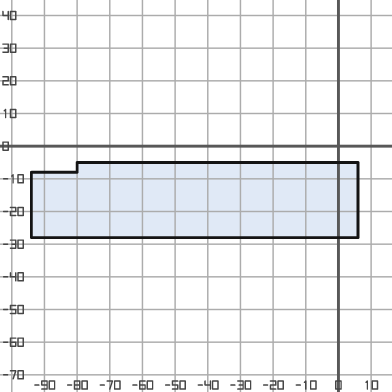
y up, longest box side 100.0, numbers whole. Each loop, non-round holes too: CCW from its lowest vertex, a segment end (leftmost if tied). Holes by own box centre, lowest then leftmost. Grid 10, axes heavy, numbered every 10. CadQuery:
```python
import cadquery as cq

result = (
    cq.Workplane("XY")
    .moveTo(-94.0, -28.0)
    .lineTo(6.0, -28.0)
    .lineTo(6.0, -5.0)
    .lineTo(-80.0, -5.0)
    .lineTo(-80.0, -8.0)
    .lineTo(-94.0, -8.0)
    .close()
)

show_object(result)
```